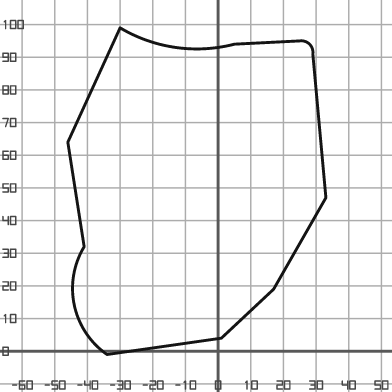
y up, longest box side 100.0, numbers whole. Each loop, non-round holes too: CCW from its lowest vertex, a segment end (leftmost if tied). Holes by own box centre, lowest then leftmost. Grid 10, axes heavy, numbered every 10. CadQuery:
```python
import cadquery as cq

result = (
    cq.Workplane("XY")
    .moveTo(-34.0, -1.0)
    .lineTo(1.0, 4.0)
    .lineTo(17.0, 19.0)
    .lineTo(33.0, 47.0)
    .lineTo(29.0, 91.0)
    .threePointArc((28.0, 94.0), (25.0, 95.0))
    .lineTo(5.0, 94.0)
    .threePointArc((-13.0, 93.0), (-30.0, 99.0))
    .lineTo(-46.0, 64.0)
    .lineTo(-41.0, 32.0)
    .threePointArc((-44.0, 14.0), (-34.0, -1.0))
    .close()
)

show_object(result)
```